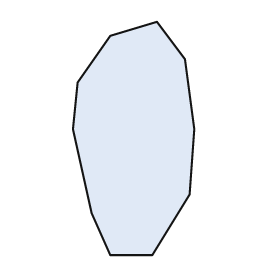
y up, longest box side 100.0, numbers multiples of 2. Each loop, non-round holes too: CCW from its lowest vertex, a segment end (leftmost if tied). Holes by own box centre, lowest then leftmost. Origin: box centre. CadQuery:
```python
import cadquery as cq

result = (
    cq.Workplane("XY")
    .moveTo(-10.0, -50.0)
    .lineTo(8.0, -50.0)
    .lineTo(24.0, -24.0)
    .lineTo(26.0, 4.0)
    .lineTo(22.0, 34.0)
    .lineTo(10.0, 50.0)
    .lineTo(-10.0, 44.0)
    .lineTo(-24.0, 24.0)
    .lineTo(-26.0, 4.0)
    .lineTo(-18.0, -32.0)
    .close()
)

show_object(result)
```